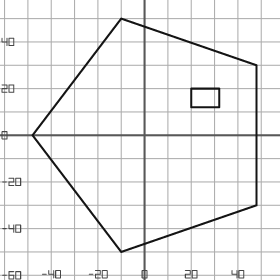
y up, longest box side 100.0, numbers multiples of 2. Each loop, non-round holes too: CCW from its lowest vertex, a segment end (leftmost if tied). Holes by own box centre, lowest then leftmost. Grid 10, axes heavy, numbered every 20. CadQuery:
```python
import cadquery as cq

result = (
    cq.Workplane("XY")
    .moveTo(-10.0, -50.0)
    .lineTo(48.0, -30.0)
    .lineTo(48.0, 30.0)
    .lineTo(-10.0, 50.0)
    .lineTo(-48.0, 0.0)
    .close()
    .moveTo(20.0, 12.0)
    .lineTo(32.0, 12.0)
    .lineTo(32.0, 20.0)
    .lineTo(20.0, 20.0)
    .close()
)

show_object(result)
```